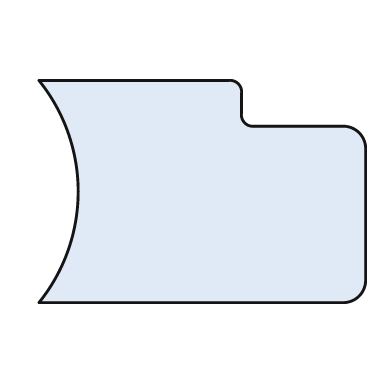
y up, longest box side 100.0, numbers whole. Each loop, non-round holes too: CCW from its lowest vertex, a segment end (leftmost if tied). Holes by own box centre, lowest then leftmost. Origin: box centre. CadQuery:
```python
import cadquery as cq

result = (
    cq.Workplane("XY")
    .moveTo(-50.0, -34.0)
    .lineTo(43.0, -34.0)
    .threePointArc((48.0, -32.0), (50.0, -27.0))
    .lineTo(50.0, 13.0)
    .threePointArc((48.0, 18.0), (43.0, 20.0))
    .lineTo(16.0, 20.0)
    .threePointArc((13.0, 21.0), (12.0, 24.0))
    .lineTo(12.0, 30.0)
    .threePointArc((11.0, 33.0), (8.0, 34.0))
    .lineTo(-50.0, 34.0)
    .threePointArc((-38.0, 0.0), (-50.0, -34.0))
    .close()
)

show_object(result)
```